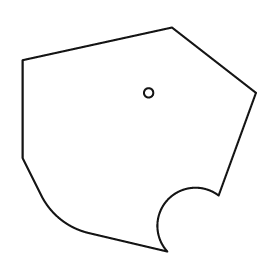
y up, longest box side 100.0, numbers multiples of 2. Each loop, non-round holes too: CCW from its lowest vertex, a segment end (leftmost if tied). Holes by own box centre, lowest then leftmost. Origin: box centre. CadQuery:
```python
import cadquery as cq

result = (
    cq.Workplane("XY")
    .moveTo(12.0, -48.0)
    .threePointArc((12.0, -26.0), (34.0, -24.0))
    .lineTo(50.0, 20.0)
    .lineTo(14.0, 48.0)
    .lineTo(-50.0, 34.0)
    .lineTo(-50.0, -8.0)
    .lineTo(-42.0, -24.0)
    .threePointArc((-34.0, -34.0), (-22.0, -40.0))
    .close()
    .moveTo(4.0, 20.0)
    .circle(2.0)
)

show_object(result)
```